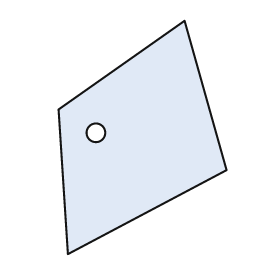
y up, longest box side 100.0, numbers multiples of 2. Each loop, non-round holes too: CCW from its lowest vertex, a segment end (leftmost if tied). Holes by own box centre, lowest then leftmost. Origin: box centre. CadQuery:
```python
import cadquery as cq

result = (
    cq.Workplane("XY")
    .moveTo(-32.0, -50.0)
    .lineTo(36.0, -14.0)
    .lineTo(18.0, 50.0)
    .lineTo(-36.0, 12.0)
    .close()
    .moveTo(-20.0, 2.0)
    .circle(4.0)
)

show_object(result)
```